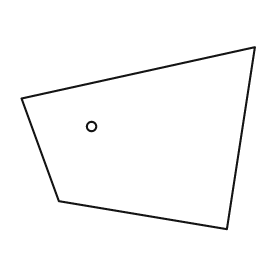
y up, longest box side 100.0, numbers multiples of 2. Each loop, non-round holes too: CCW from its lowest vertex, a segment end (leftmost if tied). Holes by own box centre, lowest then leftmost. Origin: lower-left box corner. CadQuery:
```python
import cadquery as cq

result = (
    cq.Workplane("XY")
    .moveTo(88.0, 0.0)
    .lineTo(100.0, 78.0)
    .lineTo(0.0, 56.0)
    .lineTo(16.0, 12.0)
    .close()
    .moveTo(30.0, 44.0)
    .circle(2.0)
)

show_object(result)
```